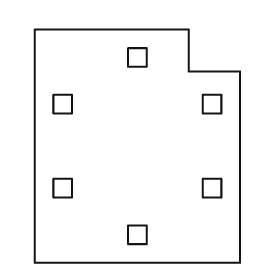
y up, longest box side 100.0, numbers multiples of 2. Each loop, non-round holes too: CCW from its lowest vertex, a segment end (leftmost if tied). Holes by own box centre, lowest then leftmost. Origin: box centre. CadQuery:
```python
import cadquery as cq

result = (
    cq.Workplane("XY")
    .moveTo(-44.0, -50.0)
    .lineTo(44.0, -50.0)
    .lineTo(44.0, 32.0)
    .lineTo(22.0, 32.0)
    .lineTo(22.0, 50.0)
    .lineTo(-44.0, 50.0)
    .close()
    .moveTo(-4.0, -42.0)
    .lineTo(4.0, -42.0)
    .lineTo(4.0, -34.0)
    .lineTo(-4.0, -34.0)
    .close()
    .moveTo(-36.0, -22.0)
    .lineTo(-28.0, -22.0)
    .lineTo(-28.0, -14.0)
    .lineTo(-36.0, -14.0)
    .close()
    .moveTo(28.0, -22.0)
    .lineTo(36.0, -22.0)
    .lineTo(36.0, -14.0)
    .lineTo(28.0, -14.0)
    .close()
    .moveTo(-36.0, 14.0)
    .lineTo(-28.0, 14.0)
    .lineTo(-28.0, 22.0)
    .lineTo(-36.0, 22.0)
    .close()
    .moveTo(28.0, 14.0)
    .lineTo(36.0, 14.0)
    .lineTo(36.0, 22.0)
    .lineTo(28.0, 22.0)
    .close()
    .moveTo(-4.0, 34.0)
    .lineTo(4.0, 34.0)
    .lineTo(4.0, 42.0)
    .lineTo(-4.0, 42.0)
    .close()
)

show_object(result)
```